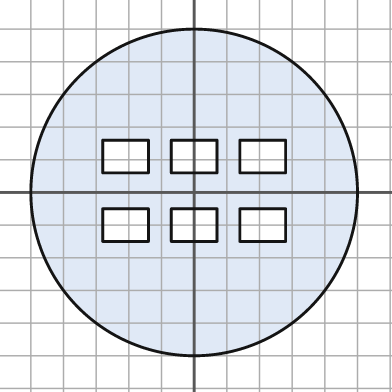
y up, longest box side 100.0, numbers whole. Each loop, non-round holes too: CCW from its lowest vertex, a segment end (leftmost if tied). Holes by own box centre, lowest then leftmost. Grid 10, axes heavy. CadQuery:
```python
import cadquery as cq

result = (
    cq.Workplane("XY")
    .moveTo(0.0, 0.0)
    .circle(50.0)
    .moveTo(-28.0, -15.0)
    .lineTo(-14.0, -15.0)
    .lineTo(-14.0, -5.0)
    .lineTo(-28.0, -5.0)
    .close()
    .moveTo(-7.0, -15.0)
    .lineTo(7.0, -15.0)
    .lineTo(7.0, -5.0)
    .lineTo(-7.0, -5.0)
    .close()
    .moveTo(14.0, -15.0)
    .lineTo(28.0, -15.0)
    .lineTo(28.0, -5.0)
    .lineTo(14.0, -5.0)
    .close()
    .moveTo(-28.0, 6.0)
    .lineTo(-14.0, 6.0)
    .lineTo(-14.0, 16.0)
    .lineTo(-28.0, 16.0)
    .close()
    .moveTo(-7.0, 6.0)
    .lineTo(7.0, 6.0)
    .lineTo(7.0, 16.0)
    .lineTo(-7.0, 16.0)
    .close()
    .moveTo(14.0, 6.0)
    .lineTo(28.0, 6.0)
    .lineTo(28.0, 16.0)
    .lineTo(14.0, 16.0)
    .close()
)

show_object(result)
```